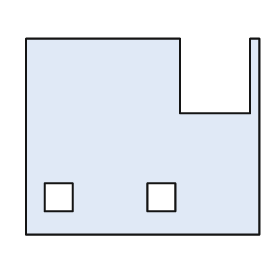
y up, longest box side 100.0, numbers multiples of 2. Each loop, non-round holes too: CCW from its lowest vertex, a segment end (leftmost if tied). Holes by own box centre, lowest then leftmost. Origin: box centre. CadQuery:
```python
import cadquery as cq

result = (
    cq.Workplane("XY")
    .moveTo(-50.0, -42.0)
    .lineTo(50.0, -42.0)
    .lineTo(50.0, 42.0)
    .lineTo(46.0, 42.0)
    .lineTo(46.0, 10.0)
    .lineTo(16.0, 10.0)
    .lineTo(16.0, 42.0)
    .lineTo(-50.0, 42.0)
    .close()
    .moveTo(-42.0, -32.0)
    .lineTo(-30.0, -32.0)
    .lineTo(-30.0, -20.0)
    .lineTo(-42.0, -20.0)
    .close()
    .moveTo(2.0, -32.0)
    .lineTo(14.0, -32.0)
    .lineTo(14.0, -20.0)
    .lineTo(2.0, -20.0)
    .close()
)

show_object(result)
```